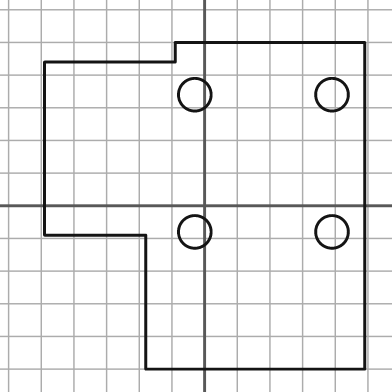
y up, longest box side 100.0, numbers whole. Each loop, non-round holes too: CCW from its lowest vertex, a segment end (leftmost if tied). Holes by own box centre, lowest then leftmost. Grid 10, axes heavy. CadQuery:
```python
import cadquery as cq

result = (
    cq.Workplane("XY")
    .moveTo(-18.0, -50.0)
    .lineTo(49.0, -50.0)
    .lineTo(49.0, 50.0)
    .lineTo(-9.0, 50.0)
    .lineTo(-9.0, 44.0)
    .lineTo(-49.0, 44.0)
    .lineTo(-49.0, -9.0)
    .lineTo(-18.0, -9.0)
    .close()
    .moveTo(-3.0, -8.0)
    .circle(5.0)
    .moveTo(39.0, -8.0)
    .circle(5.0)
    .moveTo(-3.0, 34.0)
    .circle(5.0)
    .moveTo(39.0, 34.0)
    .circle(5.0)
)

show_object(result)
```